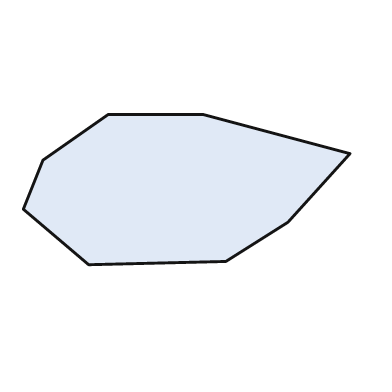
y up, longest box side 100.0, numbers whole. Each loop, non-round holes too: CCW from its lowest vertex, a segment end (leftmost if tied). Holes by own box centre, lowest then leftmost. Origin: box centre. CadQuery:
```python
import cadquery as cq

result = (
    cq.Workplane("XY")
    .moveTo(-30.0, -23.0)
    .lineTo(12.0, -22.0)
    .lineTo(31.0, -10.0)
    .lineTo(50.0, 11.0)
    .lineTo(5.0, 23.0)
    .lineTo(-24.0, 23.0)
    .lineTo(-44.0, 9.0)
    .lineTo(-50.0, -6.0)
    .close()
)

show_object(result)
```